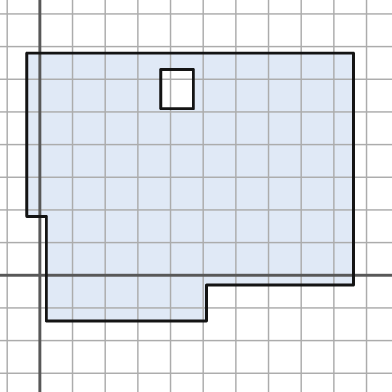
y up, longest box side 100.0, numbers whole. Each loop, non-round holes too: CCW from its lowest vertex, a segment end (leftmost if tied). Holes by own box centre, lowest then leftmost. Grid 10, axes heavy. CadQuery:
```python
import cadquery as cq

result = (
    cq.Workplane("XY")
    .moveTo(2.0, -14.0)
    .lineTo(51.0, -14.0)
    .lineTo(51.0, -3.0)
    .lineTo(96.0, -3.0)
    .lineTo(96.0, 68.0)
    .lineTo(-4.0, 68.0)
    .lineTo(-4.0, 18.0)
    .lineTo(2.0, 18.0)
    .close()
    .moveTo(37.0, 51.0)
    .lineTo(47.0, 51.0)
    .lineTo(47.0, 63.0)
    .lineTo(37.0, 63.0)
    .close()
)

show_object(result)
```